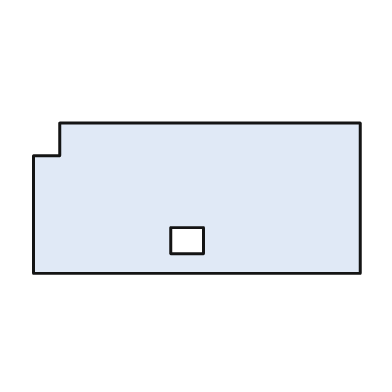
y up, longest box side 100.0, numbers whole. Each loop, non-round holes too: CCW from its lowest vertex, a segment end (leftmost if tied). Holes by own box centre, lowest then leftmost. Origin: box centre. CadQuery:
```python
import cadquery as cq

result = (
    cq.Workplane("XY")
    .moveTo(-50.0, -23.0)
    .lineTo(50.0, -23.0)
    .lineTo(50.0, 23.0)
    .lineTo(-42.0, 23.0)
    .lineTo(-42.0, 13.0)
    .lineTo(-50.0, 13.0)
    .close()
    .moveTo(-8.0, -17.0)
    .lineTo(2.0, -17.0)
    .lineTo(2.0, -9.0)
    .lineTo(-8.0, -9.0)
    .close()
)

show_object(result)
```